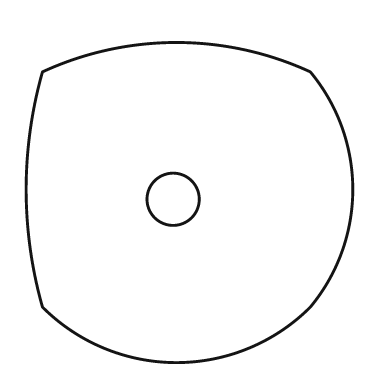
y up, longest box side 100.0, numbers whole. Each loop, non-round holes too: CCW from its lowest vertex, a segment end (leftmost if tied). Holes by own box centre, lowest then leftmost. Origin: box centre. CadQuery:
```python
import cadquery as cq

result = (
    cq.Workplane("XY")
    .moveTo(-45.0, -32.0)
    .threePointArc((-4.0, -49.0), (37.0, -32.0))
    .threePointArc((50.0, 4.0), (37.0, 40.0))
    .threePointArc((-4.0, 49.0), (-45.0, 40.0))
    .threePointArc((-50.0, 4.0), (-45.0, -32.0))
    .close()
    .moveTo(-5.0, 1.0)
    .circle(8.0)
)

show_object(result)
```